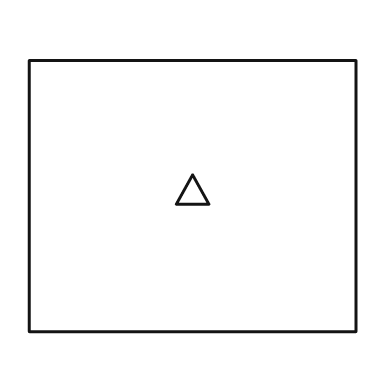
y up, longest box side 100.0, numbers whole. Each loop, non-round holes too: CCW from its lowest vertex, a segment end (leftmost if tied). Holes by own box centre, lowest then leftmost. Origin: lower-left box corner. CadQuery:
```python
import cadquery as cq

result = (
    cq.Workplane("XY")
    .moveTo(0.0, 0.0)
    .lineTo(100.0, 0.0)
    .lineTo(100.0, 83.0)
    .lineTo(0.0, 83.0)
    .close()
    .moveTo(45.0, 39.0)
    .lineTo(55.0, 39.0)
    .lineTo(50.0, 48.0)
    .close()
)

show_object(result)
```